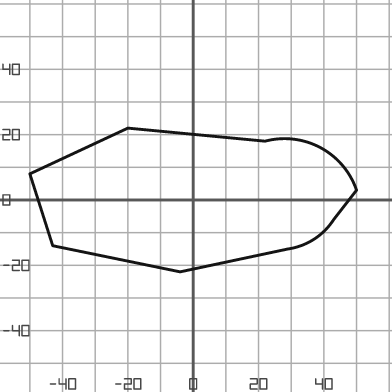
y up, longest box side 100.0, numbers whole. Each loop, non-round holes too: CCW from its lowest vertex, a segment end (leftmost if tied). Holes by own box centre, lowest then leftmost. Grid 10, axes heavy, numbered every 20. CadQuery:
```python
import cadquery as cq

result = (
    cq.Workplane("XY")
    .moveTo(-4.0, -22.0)
    .lineTo(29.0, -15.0)
    .threePointArc((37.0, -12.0), (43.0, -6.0))
    .lineTo(50.0, 3.0)
    .threePointArc((39.0, 16.0), (22.0, 18.0))
    .lineTo(-20.0, 22.0)
    .lineTo(-50.0, 8.0)
    .lineTo(-43.0, -14.0)
    .close()
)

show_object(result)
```